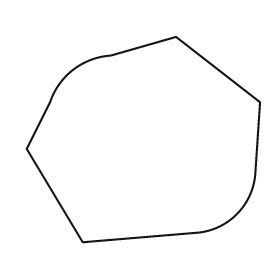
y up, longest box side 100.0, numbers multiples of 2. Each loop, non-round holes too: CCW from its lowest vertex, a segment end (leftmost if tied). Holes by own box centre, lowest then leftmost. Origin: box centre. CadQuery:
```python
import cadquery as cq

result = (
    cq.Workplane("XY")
    .moveTo(-26.0, -44.0)
    .lineTo(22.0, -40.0)
    .threePointArc((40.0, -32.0), (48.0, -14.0))
    .lineTo(50.0, 16.0)
    .lineTo(14.0, 44.0)
    .lineTo(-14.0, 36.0)
    .threePointArc((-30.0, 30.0), (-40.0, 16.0))
    .lineTo(-50.0, -4.0)
    .close()
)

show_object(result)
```